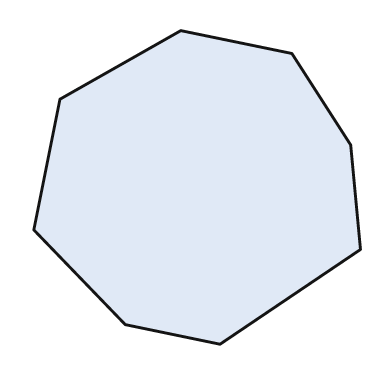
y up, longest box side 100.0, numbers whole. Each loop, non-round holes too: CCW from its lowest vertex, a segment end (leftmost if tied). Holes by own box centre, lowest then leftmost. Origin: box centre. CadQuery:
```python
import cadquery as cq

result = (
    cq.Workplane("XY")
    .moveTo(7.0, -48.0)
    .lineTo(50.0, -19.0)
    .lineTo(47.0, 13.0)
    .lineTo(29.0, 41.0)
    .lineTo(-5.0, 48.0)
    .lineTo(-42.0, 27.0)
    .lineTo(-50.0, -13.0)
    .lineTo(-22.0, -42.0)
    .close()
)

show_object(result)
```